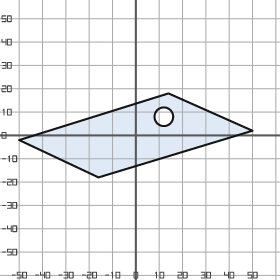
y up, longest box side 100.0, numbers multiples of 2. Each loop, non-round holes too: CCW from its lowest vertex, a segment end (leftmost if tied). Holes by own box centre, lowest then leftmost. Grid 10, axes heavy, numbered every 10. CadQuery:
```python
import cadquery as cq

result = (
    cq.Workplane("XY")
    .moveTo(-16.0, -18.0)
    .lineTo(50.0, 2.0)
    .lineTo(14.0, 18.0)
    .lineTo(-50.0, -2.0)
    .close()
    .moveTo(12.0, 8.0)
    .circle(4.0)
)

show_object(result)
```